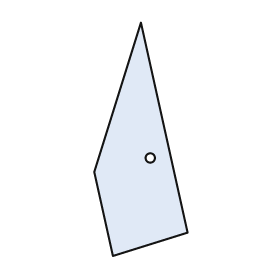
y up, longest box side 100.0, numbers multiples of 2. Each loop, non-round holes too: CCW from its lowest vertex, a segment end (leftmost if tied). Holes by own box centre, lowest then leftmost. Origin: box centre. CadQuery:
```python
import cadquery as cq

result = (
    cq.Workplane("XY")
    .moveTo(-12.0, -50.0)
    .lineTo(20.0, -40.0)
    .lineTo(0.0, 50.0)
    .lineTo(-20.0, -14.0)
    .close()
    .moveTo(4.0, -8.0)
    .circle(2.0)
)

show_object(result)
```